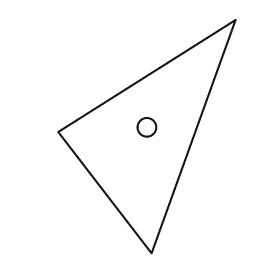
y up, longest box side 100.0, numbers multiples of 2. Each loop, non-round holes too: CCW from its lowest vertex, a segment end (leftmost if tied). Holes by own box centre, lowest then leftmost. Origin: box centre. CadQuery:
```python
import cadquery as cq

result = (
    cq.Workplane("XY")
    .moveTo(2.0, -50.0)
    .lineTo(38.0, 50.0)
    .lineTo(-38.0, 2.0)
    .close()
    .moveTo(0.0, 4.0)
    .circle(4.0)
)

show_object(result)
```